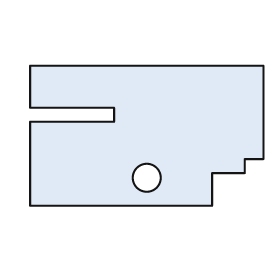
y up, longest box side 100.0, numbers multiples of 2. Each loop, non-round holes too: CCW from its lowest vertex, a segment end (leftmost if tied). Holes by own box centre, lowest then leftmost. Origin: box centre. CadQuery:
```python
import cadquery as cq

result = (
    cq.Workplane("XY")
    .moveTo(-50.0, -30.0)
    .lineTo(28.0, -30.0)
    .lineTo(28.0, -16.0)
    .lineTo(42.0, -16.0)
    .lineTo(42.0, -10.0)
    .lineTo(50.0, -10.0)
    .lineTo(50.0, 30.0)
    .lineTo(-50.0, 30.0)
    .lineTo(-50.0, 12.0)
    .lineTo(-14.0, 12.0)
    .lineTo(-14.0, 6.0)
    .lineTo(-50.0, 6.0)
    .close()
    .moveTo(0.0, -18.0)
    .circle(6.0)
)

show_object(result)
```